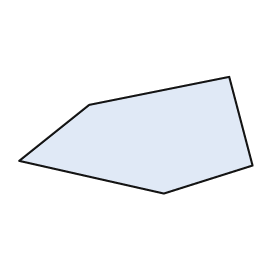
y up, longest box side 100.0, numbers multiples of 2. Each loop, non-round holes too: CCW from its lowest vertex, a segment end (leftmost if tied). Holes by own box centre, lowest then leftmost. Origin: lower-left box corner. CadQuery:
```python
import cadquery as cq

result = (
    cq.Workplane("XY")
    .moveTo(62.0, 0.0)
    .lineTo(100.0, 12.0)
    .lineTo(90.0, 50.0)
    .lineTo(30.0, 38.0)
    .lineTo(0.0, 14.0)
    .close()
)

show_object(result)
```